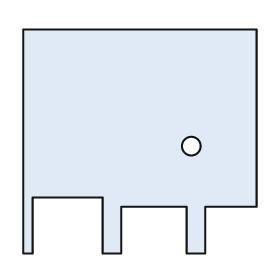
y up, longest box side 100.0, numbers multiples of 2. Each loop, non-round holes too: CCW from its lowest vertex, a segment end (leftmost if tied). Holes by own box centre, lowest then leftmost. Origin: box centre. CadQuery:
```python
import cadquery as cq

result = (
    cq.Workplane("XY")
    .moveTo(-50.0, -48.0)
    .lineTo(-46.0, -48.0)
    .lineTo(-46.0, -24.0)
    .lineTo(-16.0, -24.0)
    .lineTo(-16.0, -48.0)
    .lineTo(-8.0, -48.0)
    .lineTo(-8.0, -28.0)
    .lineTo(20.0, -28.0)
    .lineTo(20.0, -48.0)
    .lineTo(28.0, -48.0)
    .lineTo(28.0, -28.0)
    .lineTo(50.0, -28.0)
    .lineTo(50.0, 48.0)
    .lineTo(-50.0, 48.0)
    .close()
    .moveTo(22.0, -2.0)
    .circle(4.0)
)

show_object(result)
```